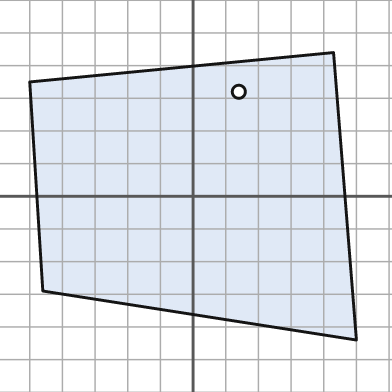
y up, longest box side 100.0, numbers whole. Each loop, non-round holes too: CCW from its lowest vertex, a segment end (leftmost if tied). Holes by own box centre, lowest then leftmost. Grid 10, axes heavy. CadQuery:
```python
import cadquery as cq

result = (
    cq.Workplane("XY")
    .moveTo(50.0, -44.0)
    .lineTo(43.0, 44.0)
    .lineTo(-50.0, 35.0)
    .lineTo(-46.0, -29.0)
    .close()
    .moveTo(14.0, 32.0)
    .circle(2.0)
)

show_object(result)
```